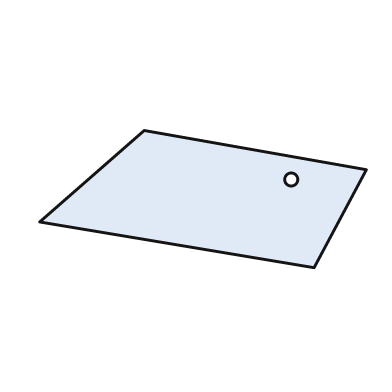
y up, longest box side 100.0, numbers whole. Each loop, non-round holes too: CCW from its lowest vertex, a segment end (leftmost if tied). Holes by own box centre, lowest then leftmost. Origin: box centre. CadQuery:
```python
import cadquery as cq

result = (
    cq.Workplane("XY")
    .moveTo(34.0, -21.0)
    .lineTo(50.0, 9.0)
    .lineTo(-18.0, 21.0)
    .lineTo(-50.0, -7.0)
    .close()
    .moveTo(27.0, 6.0)
    .circle(2.0)
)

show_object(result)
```